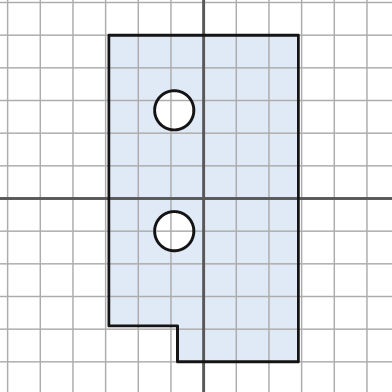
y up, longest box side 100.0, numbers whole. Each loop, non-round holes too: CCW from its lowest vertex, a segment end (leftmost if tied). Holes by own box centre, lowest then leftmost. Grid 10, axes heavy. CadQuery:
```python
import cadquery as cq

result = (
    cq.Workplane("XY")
    .moveTo(-8.0, -50.0)
    .lineTo(29.0, -50.0)
    .lineTo(29.0, 50.0)
    .lineTo(-29.0, 50.0)
    .lineTo(-29.0, -39.0)
    .lineTo(-8.0, -39.0)
    .close()
    .moveTo(-9.0, -10.0)
    .circle(6.0)
    .moveTo(-9.0, 27.0)
    .circle(6.0)
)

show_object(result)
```